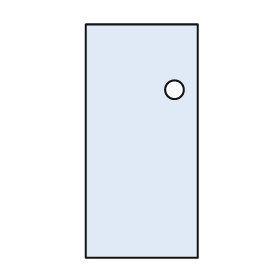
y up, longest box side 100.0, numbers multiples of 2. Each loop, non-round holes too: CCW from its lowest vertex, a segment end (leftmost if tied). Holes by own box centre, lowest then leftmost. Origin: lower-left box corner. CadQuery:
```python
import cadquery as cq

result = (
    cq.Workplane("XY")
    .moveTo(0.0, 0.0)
    .lineTo(48.0, 0.0)
    .lineTo(48.0, 100.0)
    .lineTo(0.0, 100.0)
    .close()
    .moveTo(38.0, 72.0)
    .circle(4.0)
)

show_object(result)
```